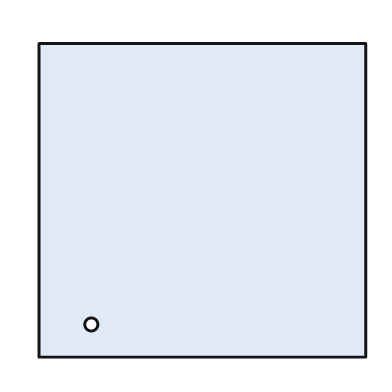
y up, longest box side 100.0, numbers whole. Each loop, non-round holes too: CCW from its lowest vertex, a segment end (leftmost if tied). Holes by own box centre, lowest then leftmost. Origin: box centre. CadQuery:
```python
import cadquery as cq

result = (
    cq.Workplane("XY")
    .moveTo(-50.0, -48.0)
    .lineTo(50.0, -48.0)
    .lineTo(50.0, 48.0)
    .lineTo(-50.0, 48.0)
    .close()
    .moveTo(-34.0, -38.0)
    .circle(2.0)
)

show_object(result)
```